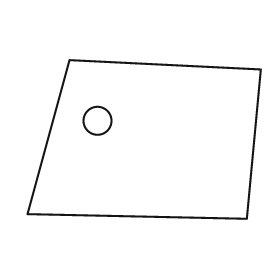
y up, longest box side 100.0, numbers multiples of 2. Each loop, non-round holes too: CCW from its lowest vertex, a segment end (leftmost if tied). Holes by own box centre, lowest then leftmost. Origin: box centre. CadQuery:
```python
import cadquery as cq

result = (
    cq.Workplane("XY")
    .moveTo(44.0, -34.0)
    .lineTo(50.0, 30.0)
    .lineTo(-32.0, 34.0)
    .lineTo(-50.0, -32.0)
    .close()
    .moveTo(-20.0, 8.0)
    .circle(6.0)
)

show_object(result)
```